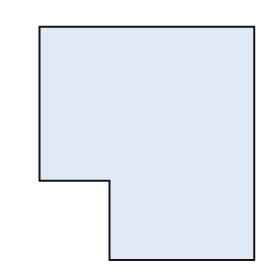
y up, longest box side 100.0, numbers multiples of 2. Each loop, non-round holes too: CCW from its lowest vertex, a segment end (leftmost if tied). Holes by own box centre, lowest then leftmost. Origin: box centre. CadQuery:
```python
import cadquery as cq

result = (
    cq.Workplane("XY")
    .moveTo(-16.0, -50.0)
    .lineTo(46.0, -50.0)
    .lineTo(46.0, 50.0)
    .lineTo(-46.0, 50.0)
    .lineTo(-46.0, -16.0)
    .lineTo(-16.0, -16.0)
    .close()
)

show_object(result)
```